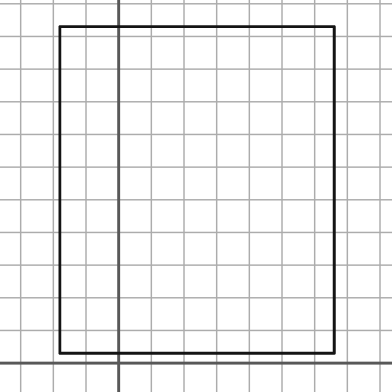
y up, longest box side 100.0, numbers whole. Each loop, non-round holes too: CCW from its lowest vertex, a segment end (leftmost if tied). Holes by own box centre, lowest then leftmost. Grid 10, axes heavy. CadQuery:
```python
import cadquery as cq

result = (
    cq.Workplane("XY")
    .moveTo(-18.0, 3.0)
    .lineTo(66.0, 3.0)
    .lineTo(66.0, 103.0)
    .lineTo(-18.0, 103.0)
    .close()
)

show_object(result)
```